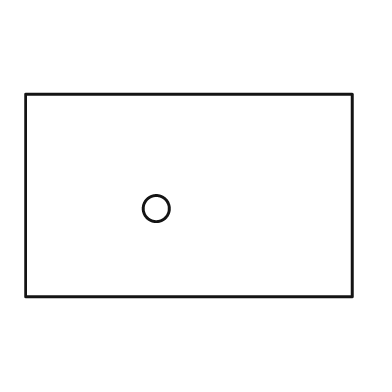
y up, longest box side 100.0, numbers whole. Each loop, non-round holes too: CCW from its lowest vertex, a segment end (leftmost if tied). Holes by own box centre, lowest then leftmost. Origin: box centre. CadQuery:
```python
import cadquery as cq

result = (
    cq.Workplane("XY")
    .moveTo(-50.0, -31.0)
    .lineTo(50.0, -31.0)
    .lineTo(50.0, 31.0)
    .lineTo(-50.0, 31.0)
    .close()
    .moveTo(-10.0, -4.0)
    .circle(4.0)
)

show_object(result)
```